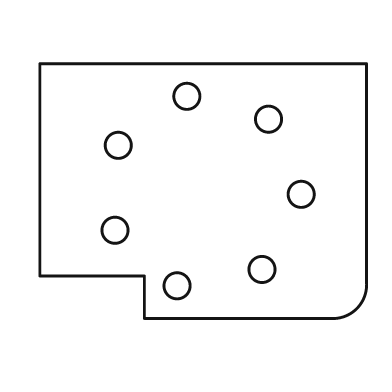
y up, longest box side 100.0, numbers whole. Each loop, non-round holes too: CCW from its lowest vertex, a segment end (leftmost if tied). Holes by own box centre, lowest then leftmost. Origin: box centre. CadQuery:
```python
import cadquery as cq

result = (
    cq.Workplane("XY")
    .moveTo(-18.0, -39.0)
    .lineTo(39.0, -39.0)
    .threePointArc((47.0, -36.0), (50.0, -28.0))
    .lineTo(50.0, 39.0)
    .lineTo(-50.0, 39.0)
    .lineTo(-50.0, -26.0)
    .lineTo(-18.0, -26.0)
    .close()
    .moveTo(-8.0, -29.0)
    .circle(4.0)
    .moveTo(18.0, -24.0)
    .circle(4.0)
    .moveTo(-27.0, -12.0)
    .circle(4.0)
    .moveTo(30.0, -1.0)
    .circle(4.0)
    .moveTo(-26.0, 14.0)
    .circle(4.0)
    .moveTo(20.0, 22.0)
    .circle(4.0)
    .moveTo(-5.0, 29.0)
    .circle(4.0)
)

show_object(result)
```